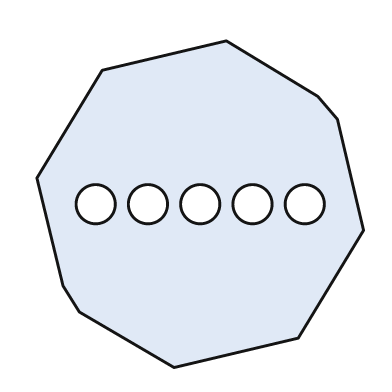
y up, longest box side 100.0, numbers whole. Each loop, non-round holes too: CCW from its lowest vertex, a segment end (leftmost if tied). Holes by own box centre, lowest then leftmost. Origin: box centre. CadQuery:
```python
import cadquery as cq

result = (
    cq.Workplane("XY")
    .moveTo(-8.0, -50.0)
    .lineTo(30.0, -41.0)
    .lineTo(50.0, -8.0)
    .lineTo(42.0, 26.0)
    .lineTo(36.0, 33.0)
    .lineTo(8.0, 50.0)
    .lineTo(-30.0, 41.0)
    .lineTo(-50.0, 8.0)
    .lineTo(-42.0, -25.0)
    .lineTo(-37.0, -33.0)
    .close()
    .moveTo(-32.0, 0.0)
    .circle(6.0)
    .moveTo(-16.0, 0.0)
    .circle(6.0)
    .moveTo(0.0, 0.0)
    .circle(6.0)
    .moveTo(16.0, 0.0)
    .circle(6.0)
    .moveTo(32.0, 0.0)
    .circle(6.0)
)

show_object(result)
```